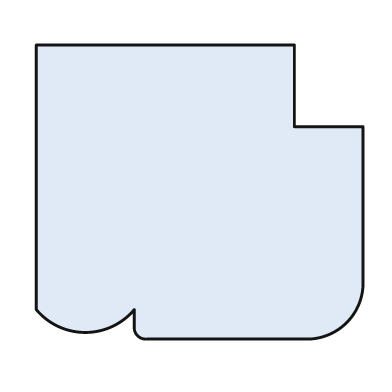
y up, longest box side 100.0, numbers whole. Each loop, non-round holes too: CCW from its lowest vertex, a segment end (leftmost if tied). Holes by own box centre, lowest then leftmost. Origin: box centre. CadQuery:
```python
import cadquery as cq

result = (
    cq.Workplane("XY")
    .moveTo(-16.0, -45.0)
    .lineTo(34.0, -45.0)
    .threePointArc((45.0, -40.0), (50.0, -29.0))
    .lineTo(50.0, 20.0)
    .lineTo(29.0, 20.0)
    .lineTo(29.0, 45.0)
    .lineTo(-50.0, 45.0)
    .lineTo(-50.0, -36.0)
    .threePointArc((-35.0, -43.0), (-20.0, -36.0))
    .lineTo(-20.0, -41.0)
    .threePointArc((-19.0, -44.0), (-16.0, -45.0))
    .close()
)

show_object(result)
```